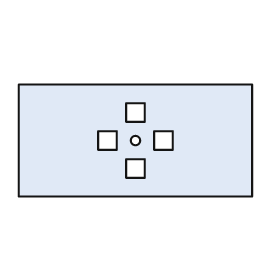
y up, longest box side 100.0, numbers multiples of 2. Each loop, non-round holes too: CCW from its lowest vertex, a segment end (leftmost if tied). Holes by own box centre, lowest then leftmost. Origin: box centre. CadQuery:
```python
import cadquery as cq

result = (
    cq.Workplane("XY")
    .moveTo(-50.0, -24.0)
    .lineTo(50.0, -24.0)
    .lineTo(50.0, 24.0)
    .lineTo(-50.0, 24.0)
    .close()
    .moveTo(-4.0, -16.0)
    .lineTo(4.0, -16.0)
    .lineTo(4.0, -8.0)
    .lineTo(-4.0, -8.0)
    .close()
    .moveTo(-16.0, -4.0)
    .lineTo(-8.0, -4.0)
    .lineTo(-8.0, 4.0)
    .lineTo(-16.0, 4.0)
    .close()
    .moveTo(0.0, 0.0)
    .circle(2.0)
    .moveTo(8.0, -4.0)
    .lineTo(16.0, -4.0)
    .lineTo(16.0, 4.0)
    .lineTo(8.0, 4.0)
    .close()
    .moveTo(-4.0, 8.0)
    .lineTo(4.0, 8.0)
    .lineTo(4.0, 16.0)
    .lineTo(-4.0, 16.0)
    .close()
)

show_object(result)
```